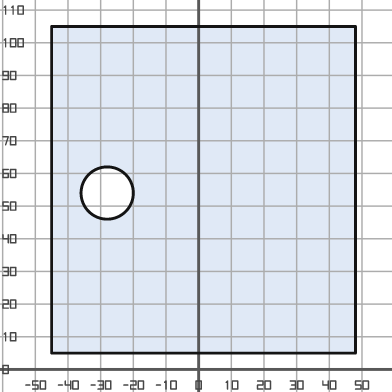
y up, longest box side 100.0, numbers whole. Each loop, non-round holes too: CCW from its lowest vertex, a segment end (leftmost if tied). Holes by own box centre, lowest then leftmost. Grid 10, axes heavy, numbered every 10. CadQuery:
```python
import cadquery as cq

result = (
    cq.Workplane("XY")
    .moveTo(-45.0, 5.0)
    .lineTo(48.0, 5.0)
    .lineTo(48.0, 105.0)
    .lineTo(-45.0, 105.0)
    .close()
    .moveTo(-28.0, 54.0)
    .circle(8.0)
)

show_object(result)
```